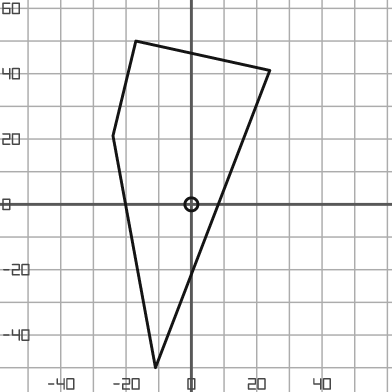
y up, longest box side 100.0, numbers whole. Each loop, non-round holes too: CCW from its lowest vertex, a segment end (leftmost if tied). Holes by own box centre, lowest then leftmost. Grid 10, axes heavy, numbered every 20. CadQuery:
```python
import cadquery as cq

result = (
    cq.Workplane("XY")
    .moveTo(-11.0, -50.0)
    .lineTo(24.0, 41.0)
    .lineTo(-17.0, 50.0)
    .lineTo(-24.0, 21.0)
    .close()
    .moveTo(0.0, 0.0)
    .circle(2.0)
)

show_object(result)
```